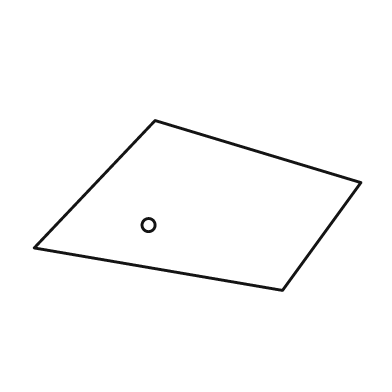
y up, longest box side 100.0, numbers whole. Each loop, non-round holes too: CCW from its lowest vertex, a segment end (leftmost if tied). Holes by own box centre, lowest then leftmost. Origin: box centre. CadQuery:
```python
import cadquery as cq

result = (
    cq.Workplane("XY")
    .moveTo(26.0, -26.0)
    .lineTo(50.0, 7.0)
    .lineTo(-13.0, 26.0)
    .lineTo(-50.0, -13.0)
    .close()
    .moveTo(-15.0, -6.0)
    .circle(2.0)
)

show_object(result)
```